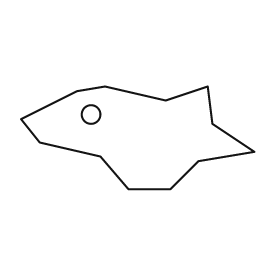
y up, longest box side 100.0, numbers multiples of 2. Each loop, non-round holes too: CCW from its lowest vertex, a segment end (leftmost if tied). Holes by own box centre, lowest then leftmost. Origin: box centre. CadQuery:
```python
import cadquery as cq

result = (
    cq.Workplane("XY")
    .moveTo(-4.0, -22.0)
    .lineTo(14.0, -22.0)
    .lineTo(26.0, -10.0)
    .lineTo(50.0, -6.0)
    .lineTo(32.0, 6.0)
    .lineTo(30.0, 22.0)
    .lineTo(12.0, 16.0)
    .lineTo(-14.0, 22.0)
    .lineTo(-26.0, 20.0)
    .lineTo(-50.0, 8.0)
    .lineTo(-42.0, -2.0)
    .lineTo(-16.0, -8.0)
    .close()
    .moveTo(-20.0, 10.0)
    .circle(4.0)
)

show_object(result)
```